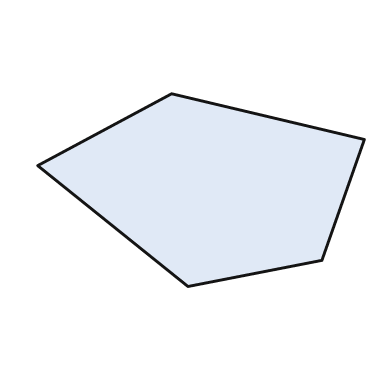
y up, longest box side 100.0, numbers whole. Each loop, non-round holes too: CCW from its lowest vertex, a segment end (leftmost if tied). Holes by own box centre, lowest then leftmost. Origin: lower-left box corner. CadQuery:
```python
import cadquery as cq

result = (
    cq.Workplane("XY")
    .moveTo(46.0, 0.0)
    .lineTo(87.0, 8.0)
    .lineTo(100.0, 45.0)
    .lineTo(41.0, 59.0)
    .lineTo(0.0, 37.0)
    .close()
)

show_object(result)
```